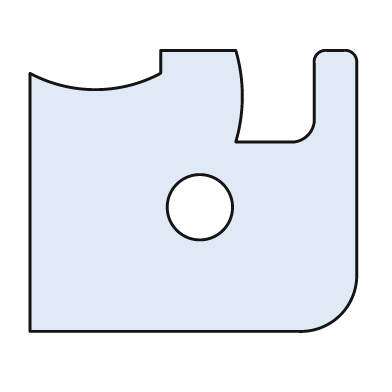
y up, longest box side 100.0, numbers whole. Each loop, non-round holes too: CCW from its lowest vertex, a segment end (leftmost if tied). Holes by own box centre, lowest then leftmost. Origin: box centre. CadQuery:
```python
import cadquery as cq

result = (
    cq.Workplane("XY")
    .moveTo(-50.0, -43.0)
    .lineTo(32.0, -43.0)
    .threePointArc((45.0, -38.0), (50.0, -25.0))
    .lineTo(50.0, 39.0)
    .threePointArc((49.0, 42.0), (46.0, 43.0))
    .lineTo(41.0, 43.0)
    .threePointArc((38.0, 42.0), (37.0, 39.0))
    .lineTo(37.0, 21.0)
    .threePointArc((35.0, 17.0), (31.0, 15.0))
    .lineTo(13.0, 15.0)
    .threePointArc((15.0, 29.0), (13.0, 43.0))
    .lineTo(-10.0, 43.0)
    .lineTo(-10.0, 36.0)
    .threePointArc((-30.0, 31.0), (-50.0, 36.0))
    .close()
    .moveTo(2.0, -5.0)
    .circle(10.0)
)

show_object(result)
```